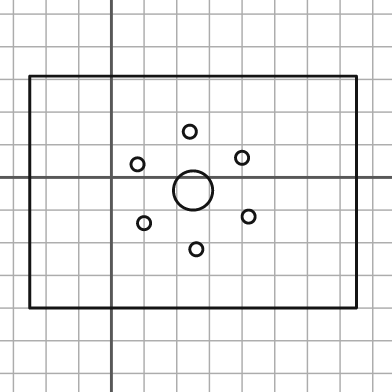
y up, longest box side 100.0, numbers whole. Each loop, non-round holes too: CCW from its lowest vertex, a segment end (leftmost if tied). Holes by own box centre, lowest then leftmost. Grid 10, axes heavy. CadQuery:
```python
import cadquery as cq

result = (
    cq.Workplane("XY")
    .moveTo(-25.0, -40.0)
    .lineTo(75.0, -40.0)
    .lineTo(75.0, 31.0)
    .lineTo(-25.0, 31.0)
    .close()
    .moveTo(26.0, -22.0)
    .circle(2.0)
    .moveTo(10.0, -14.0)
    .circle(2.0)
    .moveTo(42.0, -12.0)
    .circle(2.0)
    .moveTo(25.0, -4.0)
    .circle(6.0)
    .moveTo(8.0, 4.0)
    .circle(2.0)
    .moveTo(40.0, 6.0)
    .circle(2.0)
    .moveTo(24.0, 14.0)
    .circle(2.0)
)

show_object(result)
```